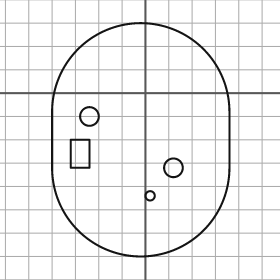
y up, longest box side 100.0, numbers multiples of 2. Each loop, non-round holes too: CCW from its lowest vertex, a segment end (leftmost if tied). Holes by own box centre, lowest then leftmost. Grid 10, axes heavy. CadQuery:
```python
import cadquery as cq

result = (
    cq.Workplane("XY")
    .moveTo(-40.0, -32.0)
    .threePointArc((-2.0, -70.0), (36.0, -32.0))
    .lineTo(36.0, -8.0)
    .threePointArc((-2.0, 30.0), (-40.0, -8.0))
    .close()
    .moveTo(2.0, -44.0)
    .circle(2.0)
    .moveTo(12.0, -32.0)
    .circle(4.0)
    .moveTo(-32.0, -32.0)
    .lineTo(-24.0, -32.0)
    .lineTo(-24.0, -20.0)
    .lineTo(-32.0, -20.0)
    .close()
    .moveTo(-24.0, -10.0)
    .circle(4.0)
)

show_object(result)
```